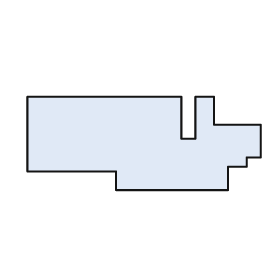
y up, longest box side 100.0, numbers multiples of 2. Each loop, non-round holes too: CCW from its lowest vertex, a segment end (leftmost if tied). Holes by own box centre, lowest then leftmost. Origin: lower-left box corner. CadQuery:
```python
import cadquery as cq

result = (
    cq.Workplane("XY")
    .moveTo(38.0, 0.0)
    .lineTo(86.0, 0.0)
    .lineTo(86.0, 10.0)
    .lineTo(94.0, 10.0)
    .lineTo(94.0, 14.0)
    .lineTo(100.0, 14.0)
    .lineTo(100.0, 28.0)
    .lineTo(80.0, 28.0)
    .lineTo(80.0, 40.0)
    .lineTo(72.0, 40.0)
    .lineTo(72.0, 22.0)
    .lineTo(66.0, 22.0)
    .lineTo(66.0, 40.0)
    .lineTo(0.0, 40.0)
    .lineTo(0.0, 8.0)
    .lineTo(38.0, 8.0)
    .close()
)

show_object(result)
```